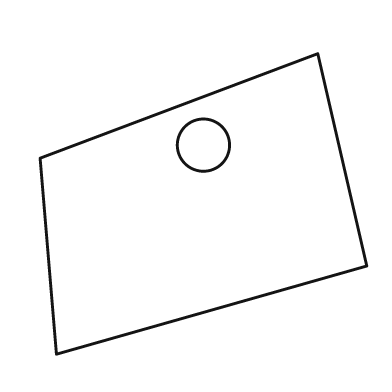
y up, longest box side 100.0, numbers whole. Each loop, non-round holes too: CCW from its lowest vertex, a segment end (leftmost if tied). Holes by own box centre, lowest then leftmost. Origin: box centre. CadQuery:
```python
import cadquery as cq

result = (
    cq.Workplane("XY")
    .moveTo(-45.0, -46.0)
    .lineTo(50.0, -19.0)
    .lineTo(35.0, 46.0)
    .lineTo(-50.0, 14.0)
    .close()
    .moveTo(0.0, 18.0)
    .circle(8.0)
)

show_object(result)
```